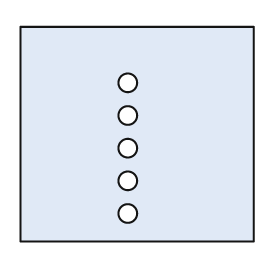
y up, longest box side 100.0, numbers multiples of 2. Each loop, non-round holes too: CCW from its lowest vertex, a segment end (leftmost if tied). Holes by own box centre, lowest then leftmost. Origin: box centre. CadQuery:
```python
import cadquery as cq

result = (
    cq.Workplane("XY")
    .moveTo(-50.0, -46.0)
    .lineTo(50.0, -46.0)
    .lineTo(50.0, 46.0)
    .lineTo(-50.0, 46.0)
    .close()
    .moveTo(-4.0, -34.0)
    .circle(4.0)
    .moveTo(-4.0, -20.0)
    .circle(4.0)
    .moveTo(-4.0, -6.0)
    .circle(4.0)
    .moveTo(-4.0, 8.0)
    .circle(4.0)
    .moveTo(-4.0, 22.0)
    .circle(4.0)
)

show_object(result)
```